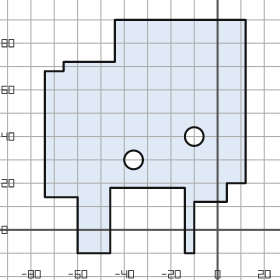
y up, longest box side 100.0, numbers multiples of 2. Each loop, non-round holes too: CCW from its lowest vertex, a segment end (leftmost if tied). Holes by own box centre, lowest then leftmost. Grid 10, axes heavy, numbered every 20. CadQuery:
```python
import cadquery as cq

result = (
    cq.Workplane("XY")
    .moveTo(-60.0, -10.0)
    .lineTo(-46.0, -10.0)
    .lineTo(-46.0, 18.0)
    .lineTo(-14.0, 18.0)
    .lineTo(-14.0, -10.0)
    .lineTo(-10.0, -10.0)
    .lineTo(-10.0, 12.0)
    .lineTo(4.0, 12.0)
    .lineTo(4.0, 20.0)
    .lineTo(12.0, 20.0)
    .lineTo(12.0, 90.0)
    .lineTo(-44.0, 90.0)
    .lineTo(-44.0, 72.0)
    .lineTo(-66.0, 72.0)
    .lineTo(-66.0, 68.0)
    .lineTo(-74.0, 68.0)
    .lineTo(-74.0, 14.0)
    .lineTo(-60.0, 14.0)
    .close()
    .moveTo(-36.0, 30.0)
    .circle(4.0)
    .moveTo(-10.0, 40.0)
    .circle(4.0)
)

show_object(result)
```